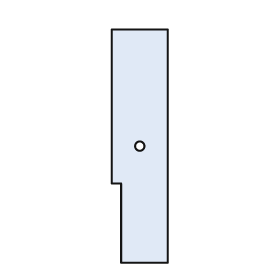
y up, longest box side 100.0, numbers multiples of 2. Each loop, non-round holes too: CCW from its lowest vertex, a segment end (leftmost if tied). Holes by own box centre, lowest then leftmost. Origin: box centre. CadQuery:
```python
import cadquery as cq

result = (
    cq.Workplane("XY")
    .moveTo(-8.0, -50.0)
    .lineTo(12.0, -50.0)
    .lineTo(12.0, 50.0)
    .lineTo(-12.0, 50.0)
    .lineTo(-12.0, -16.0)
    .lineTo(-8.0, -16.0)
    .close()
    .moveTo(0.0, 0.0)
    .circle(2.0)
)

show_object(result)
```